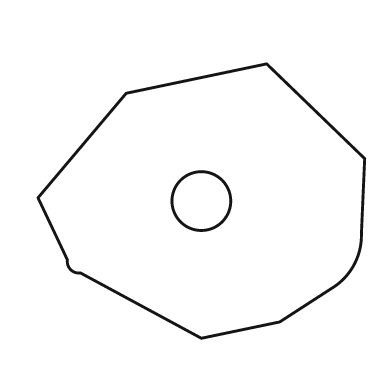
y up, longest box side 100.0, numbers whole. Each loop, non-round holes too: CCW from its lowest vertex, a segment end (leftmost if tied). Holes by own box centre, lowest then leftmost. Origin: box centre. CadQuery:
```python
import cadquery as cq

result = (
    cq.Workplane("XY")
    .moveTo(0.0, -42.0)
    .lineTo(24.0, -37.0)
    .lineTo(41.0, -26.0)
    .threePointArc((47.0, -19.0), (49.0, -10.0))
    .lineTo(50.0, 13.0)
    .lineTo(20.0, 42.0)
    .lineTo(-23.0, 33.0)
    .lineTo(-50.0, 1.0)
    .lineTo(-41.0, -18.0)
    .threePointArc((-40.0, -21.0), (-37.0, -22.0))
    .close()
    .moveTo(0.0, 0.0)
    .circle(9.0)
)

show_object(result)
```